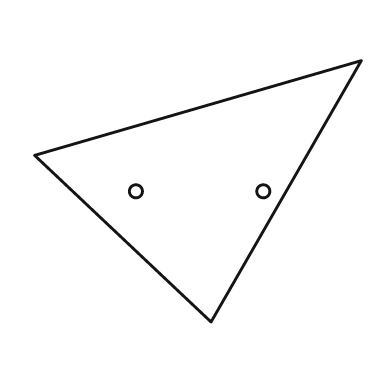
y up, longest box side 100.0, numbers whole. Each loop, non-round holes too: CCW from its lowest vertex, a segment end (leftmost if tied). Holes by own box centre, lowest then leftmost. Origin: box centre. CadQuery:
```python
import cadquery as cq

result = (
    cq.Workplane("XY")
    .moveTo(4.0, -40.0)
    .lineTo(50.0, 40.0)
    .lineTo(-50.0, 11.0)
    .close()
    .moveTo(-19.0, 0.0)
    .circle(2.0)
    .moveTo(20.0, 0.0)
    .circle(2.0)
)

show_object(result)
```